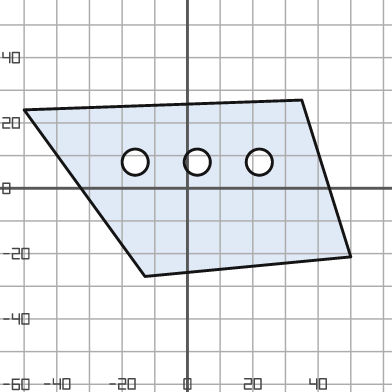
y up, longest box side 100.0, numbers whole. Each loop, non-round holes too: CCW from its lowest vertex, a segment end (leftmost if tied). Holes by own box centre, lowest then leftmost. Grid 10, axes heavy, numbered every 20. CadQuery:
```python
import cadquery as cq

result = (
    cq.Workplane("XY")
    .moveTo(-13.0, -27.0)
    .lineTo(50.0, -21.0)
    .lineTo(35.0, 27.0)
    .lineTo(-50.0, 24.0)
    .close()
    .moveTo(-16.0, 8.0)
    .circle(4.0)
    .moveTo(3.0, 8.0)
    .circle(4.0)
    .moveTo(22.0, 8.0)
    .circle(4.0)
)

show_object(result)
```